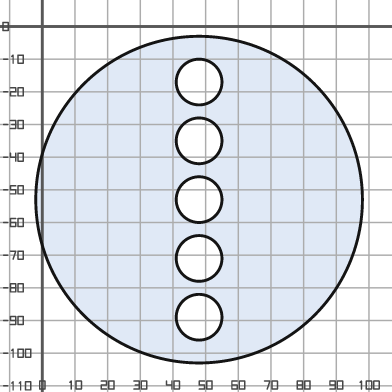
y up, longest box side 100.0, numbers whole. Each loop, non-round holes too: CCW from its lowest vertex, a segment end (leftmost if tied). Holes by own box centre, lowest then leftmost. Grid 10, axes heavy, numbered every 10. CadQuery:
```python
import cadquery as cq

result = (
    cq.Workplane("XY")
    .moveTo(48.0, -53.0)
    .circle(50.0)
    .moveTo(48.0, -89.0)
    .circle(7.0)
    .moveTo(48.0, -71.0)
    .circle(7.0)
    .moveTo(48.0, -53.0)
    .circle(7.0)
    .moveTo(48.0, -35.0)
    .circle(7.0)
    .moveTo(48.0, -17.0)
    .circle(7.0)
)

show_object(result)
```